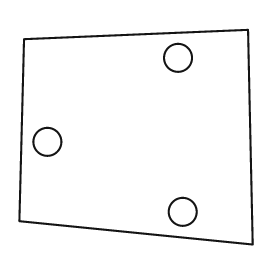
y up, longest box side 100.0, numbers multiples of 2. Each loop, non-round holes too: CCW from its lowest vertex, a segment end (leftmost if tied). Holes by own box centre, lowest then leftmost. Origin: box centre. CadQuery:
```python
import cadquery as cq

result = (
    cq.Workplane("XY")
    .moveTo(50.0, -46.0)
    .lineTo(48.0, 46.0)
    .lineTo(-48.0, 42.0)
    .lineTo(-50.0, -36.0)
    .close()
    .moveTo(20.0, -32.0)
    .circle(6.0)
    .moveTo(-38.0, -2.0)
    .circle(6.0)
    .moveTo(18.0, 34.0)
    .circle(6.0)
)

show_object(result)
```